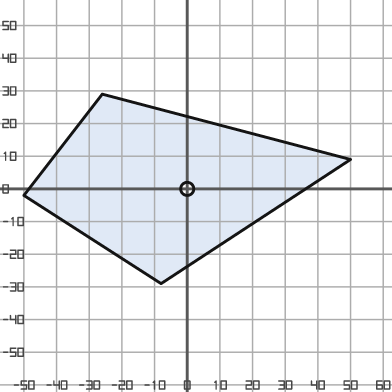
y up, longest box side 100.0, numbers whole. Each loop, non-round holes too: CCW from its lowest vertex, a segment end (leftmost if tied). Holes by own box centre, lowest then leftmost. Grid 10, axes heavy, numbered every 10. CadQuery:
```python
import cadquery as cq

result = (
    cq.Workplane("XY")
    .moveTo(-8.0, -29.0)
    .lineTo(50.0, 9.0)
    .lineTo(-26.0, 29.0)
    .lineTo(-50.0, -2.0)
    .close()
    .moveTo(0.0, 0.0)
    .circle(2.0)
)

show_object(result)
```